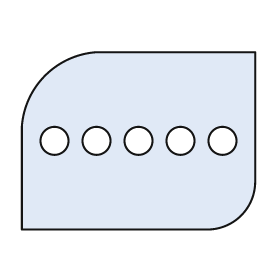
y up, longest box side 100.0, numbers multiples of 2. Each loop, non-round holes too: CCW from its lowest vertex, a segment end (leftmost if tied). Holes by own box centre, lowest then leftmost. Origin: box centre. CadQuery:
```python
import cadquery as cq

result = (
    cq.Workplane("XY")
    .moveTo(-50.0, -38.0)
    .lineTo(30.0, -38.0)
    .threePointArc((44.0, -32.0), (50.0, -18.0))
    .lineTo(50.0, 38.0)
    .lineTo(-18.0, 38.0)
    .threePointArc((-40.0, 28.0), (-50.0, 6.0))
    .close()
    .moveTo(-36.0, 0.0)
    .circle(6.0)
    .moveTo(-18.0, 0.0)
    .circle(6.0)
    .moveTo(0.0, 0.0)
    .circle(6.0)
    .moveTo(18.0, 0.0)
    .circle(6.0)
    .moveTo(36.0, 0.0)
    .circle(6.0)
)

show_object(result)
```